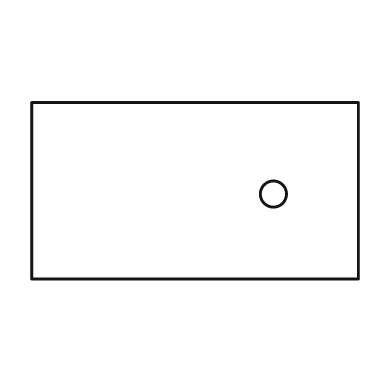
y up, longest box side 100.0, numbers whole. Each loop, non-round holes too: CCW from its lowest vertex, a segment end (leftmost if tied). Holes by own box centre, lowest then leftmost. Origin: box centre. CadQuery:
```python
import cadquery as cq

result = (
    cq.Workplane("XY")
    .moveTo(-50.0, -27.0)
    .lineTo(50.0, -27.0)
    .lineTo(50.0, 27.0)
    .lineTo(-50.0, 27.0)
    .close()
    .moveTo(24.0, -1.0)
    .circle(4.0)
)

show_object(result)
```